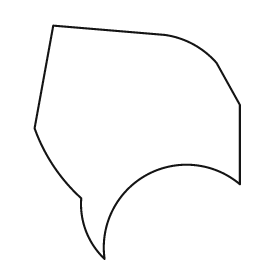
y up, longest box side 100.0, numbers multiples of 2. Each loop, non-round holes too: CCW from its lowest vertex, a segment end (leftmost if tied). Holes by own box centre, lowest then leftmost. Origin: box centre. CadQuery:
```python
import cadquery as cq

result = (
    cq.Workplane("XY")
    .moveTo(-14.0, -50.0)
    .threePointArc((4.0, -14.0), (44.0, -18.0))
    .lineTo(44.0, 16.0)
    .lineTo(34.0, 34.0)
    .threePointArc((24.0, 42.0), (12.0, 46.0))
    .lineTo(-36.0, 50.0)
    .lineTo(-44.0, 6.0)
    .threePointArc((-36.0, -10.0), (-24.0, -24.0))
    .threePointArc((-22.0, -38.0), (-14.0, -50.0))
    .close()
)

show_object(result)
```